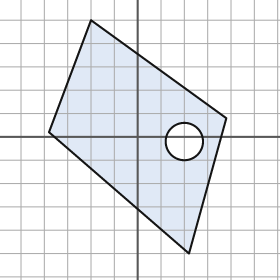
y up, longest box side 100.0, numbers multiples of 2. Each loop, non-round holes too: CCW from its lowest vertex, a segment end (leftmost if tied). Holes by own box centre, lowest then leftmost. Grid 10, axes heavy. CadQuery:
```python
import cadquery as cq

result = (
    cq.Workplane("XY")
    .moveTo(22.0, -50.0)
    .lineTo(38.0, 8.0)
    .lineTo(-20.0, 50.0)
    .lineTo(-38.0, 2.0)
    .close()
    .moveTo(20.0, -2.0)
    .circle(8.0)
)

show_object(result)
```